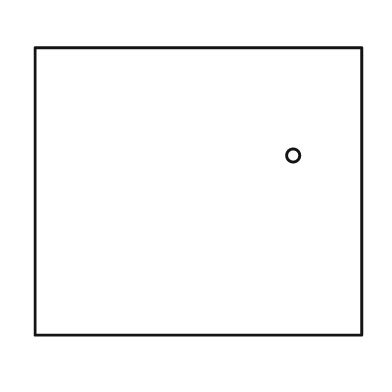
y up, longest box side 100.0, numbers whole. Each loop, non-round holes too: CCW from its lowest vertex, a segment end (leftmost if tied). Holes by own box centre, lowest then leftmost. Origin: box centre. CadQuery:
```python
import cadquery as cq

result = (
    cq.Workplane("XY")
    .moveTo(-50.0, -44.0)
    .lineTo(50.0, -44.0)
    .lineTo(50.0, 44.0)
    .lineTo(-50.0, 44.0)
    .close()
    .moveTo(29.0, 11.0)
    .circle(2.0)
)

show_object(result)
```